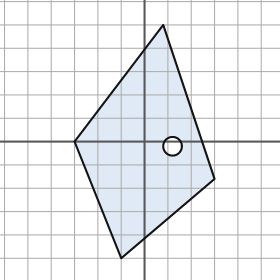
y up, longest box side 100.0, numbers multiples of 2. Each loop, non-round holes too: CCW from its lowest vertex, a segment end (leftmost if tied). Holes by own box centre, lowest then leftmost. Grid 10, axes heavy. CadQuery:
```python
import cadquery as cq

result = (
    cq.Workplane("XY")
    .moveTo(-10.0, -50.0)
    .lineTo(30.0, -16.0)
    .lineTo(8.0, 50.0)
    .lineTo(-30.0, 0.0)
    .close()
    .moveTo(12.0, -2.0)
    .circle(4.0)
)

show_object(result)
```